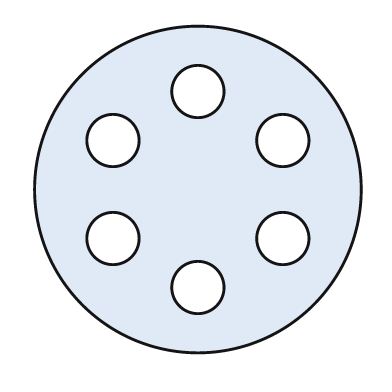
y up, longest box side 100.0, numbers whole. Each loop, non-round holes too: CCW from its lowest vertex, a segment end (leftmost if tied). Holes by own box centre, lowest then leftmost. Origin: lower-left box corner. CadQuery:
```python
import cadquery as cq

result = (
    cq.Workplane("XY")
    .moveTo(50.0, 50.0)
    .circle(50.0)
    .moveTo(50.0, 20.0)
    .circle(8.0)
    .moveTo(24.0, 35.0)
    .circle(8.0)
    .moveTo(76.0, 35.0)
    .circle(8.0)
    .moveTo(24.0, 65.0)
    .circle(8.0)
    .moveTo(76.0, 65.0)
    .circle(8.0)
    .moveTo(50.0, 80.0)
    .circle(8.0)
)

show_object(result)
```